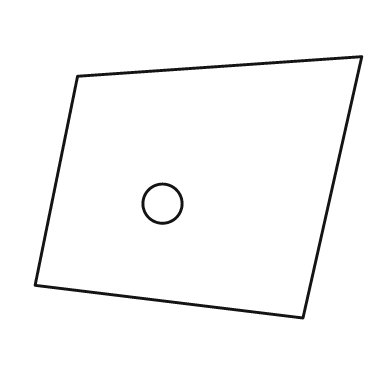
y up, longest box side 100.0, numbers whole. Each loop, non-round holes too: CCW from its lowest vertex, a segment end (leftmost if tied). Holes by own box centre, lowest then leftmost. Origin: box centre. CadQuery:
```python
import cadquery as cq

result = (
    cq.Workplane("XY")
    .moveTo(32.0, -40.0)
    .lineTo(50.0, 40.0)
    .lineTo(-37.0, 34.0)
    .lineTo(-50.0, -30.0)
    .close()
    .moveTo(-11.0, -5.0)
    .circle(6.0)
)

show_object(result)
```